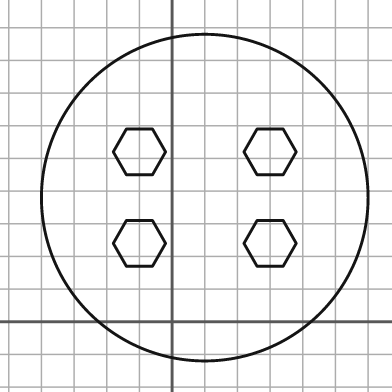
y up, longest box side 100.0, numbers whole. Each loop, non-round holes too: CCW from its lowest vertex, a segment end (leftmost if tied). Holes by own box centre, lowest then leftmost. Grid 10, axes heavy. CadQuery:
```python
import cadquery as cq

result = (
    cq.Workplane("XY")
    .moveTo(10.0, 38.0)
    .circle(50.0)
    .moveTo(-14.0, 17.0)
    .lineTo(-6.0, 17.0)
    .lineTo(-2.0, 24.0)
    .lineTo(-6.0, 31.0)
    .lineTo(-14.0, 31.0)
    .lineTo(-18.0, 24.0)
    .close()
    .moveTo(26.0, 17.0)
    .lineTo(34.0, 17.0)
    .lineTo(38.0, 24.0)
    .lineTo(34.0, 31.0)
    .lineTo(26.0, 31.0)
    .lineTo(22.0, 24.0)
    .close()
    .moveTo(-14.0, 45.0)
    .lineTo(-6.0, 45.0)
    .lineTo(-2.0, 52.0)
    .lineTo(-6.0, 59.0)
    .lineTo(-14.0, 59.0)
    .lineTo(-18.0, 52.0)
    .close()
    .moveTo(26.0, 45.0)
    .lineTo(34.0, 45.0)
    .lineTo(38.0, 52.0)
    .lineTo(34.0, 59.0)
    .lineTo(26.0, 59.0)
    .lineTo(22.0, 52.0)
    .close()
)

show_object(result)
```